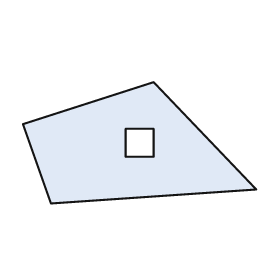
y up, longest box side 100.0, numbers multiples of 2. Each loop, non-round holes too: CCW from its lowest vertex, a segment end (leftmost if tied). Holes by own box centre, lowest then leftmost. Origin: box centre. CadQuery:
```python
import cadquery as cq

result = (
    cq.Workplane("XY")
    .moveTo(-38.0, -26.0)
    .lineTo(50.0, -20.0)
    .lineTo(6.0, 26.0)
    .lineTo(-50.0, 8.0)
    .close()
    .moveTo(-6.0, -6.0)
    .lineTo(6.0, -6.0)
    .lineTo(6.0, 6.0)
    .lineTo(-6.0, 6.0)
    .close()
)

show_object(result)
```